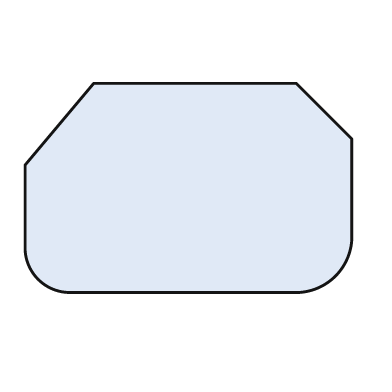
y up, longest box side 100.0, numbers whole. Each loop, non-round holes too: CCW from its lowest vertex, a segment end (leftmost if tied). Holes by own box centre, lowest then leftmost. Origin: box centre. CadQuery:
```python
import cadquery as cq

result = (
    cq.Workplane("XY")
    .moveTo(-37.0, -32.0)
    .lineTo(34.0, -32.0)
    .threePointArc((45.0, -27.0), (50.0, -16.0))
    .lineTo(50.0, 15.0)
    .lineTo(33.0, 32.0)
    .lineTo(-29.0, 32.0)
    .lineTo(-50.0, 7.0)
    .lineTo(-50.0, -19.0)
    .threePointArc((-46.0, -28.0), (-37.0, -32.0))
    .close()
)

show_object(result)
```